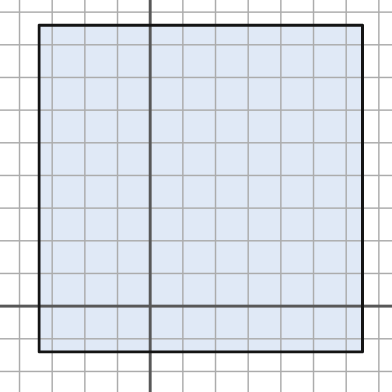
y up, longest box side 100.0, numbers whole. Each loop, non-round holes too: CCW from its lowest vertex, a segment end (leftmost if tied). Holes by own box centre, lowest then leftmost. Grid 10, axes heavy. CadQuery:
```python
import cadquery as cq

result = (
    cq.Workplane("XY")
    .moveTo(-34.0, -14.0)
    .lineTo(65.0, -14.0)
    .lineTo(65.0, 86.0)
    .lineTo(-34.0, 86.0)
    .close()
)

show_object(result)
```